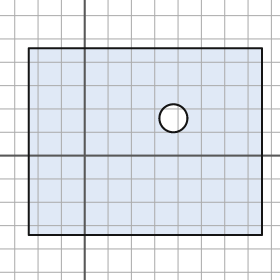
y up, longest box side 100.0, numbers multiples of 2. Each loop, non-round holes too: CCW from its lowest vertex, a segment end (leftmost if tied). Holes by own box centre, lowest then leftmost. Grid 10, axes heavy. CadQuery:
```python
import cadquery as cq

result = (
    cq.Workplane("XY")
    .moveTo(-24.0, -34.0)
    .lineTo(76.0, -34.0)
    .lineTo(76.0, 46.0)
    .lineTo(-24.0, 46.0)
    .close()
    .moveTo(38.0, 16.0)
    .circle(6.0)
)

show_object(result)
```